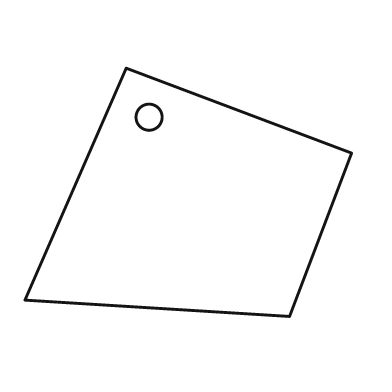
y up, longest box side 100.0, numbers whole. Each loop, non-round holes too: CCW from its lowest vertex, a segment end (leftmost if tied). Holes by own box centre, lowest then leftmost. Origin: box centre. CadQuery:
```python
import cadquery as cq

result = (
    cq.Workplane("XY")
    .moveTo(31.0, -38.0)
    .lineTo(50.0, 12.0)
    .lineTo(-19.0, 38.0)
    .lineTo(-50.0, -33.0)
    .close()
    .moveTo(-12.0, 23.0)
    .circle(4.0)
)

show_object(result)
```